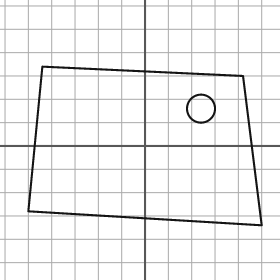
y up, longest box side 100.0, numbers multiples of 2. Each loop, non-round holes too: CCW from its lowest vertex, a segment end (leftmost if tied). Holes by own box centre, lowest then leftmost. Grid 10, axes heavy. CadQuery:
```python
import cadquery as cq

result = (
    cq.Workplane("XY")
    .moveTo(50.0, -34.0)
    .lineTo(42.0, 30.0)
    .lineTo(-44.0, 34.0)
    .lineTo(-50.0, -28.0)
    .close()
    .moveTo(24.0, 16.0)
    .circle(6.0)
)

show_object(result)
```